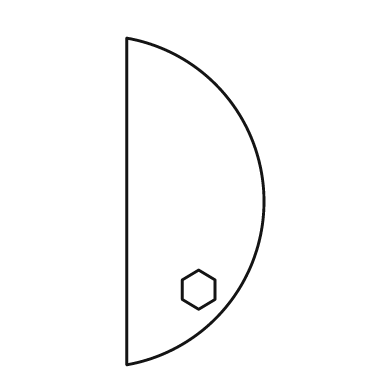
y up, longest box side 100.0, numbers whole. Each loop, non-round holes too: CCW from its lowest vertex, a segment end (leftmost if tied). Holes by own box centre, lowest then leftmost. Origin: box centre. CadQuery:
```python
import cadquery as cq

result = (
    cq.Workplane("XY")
    .moveTo(-21.0, -50.0)
    .threePointArc((21.0, 0.0), (-21.0, 50.0))
    .close()
    .moveTo(1.0, -33.0)
    .lineTo(6.0, -30.0)
    .lineTo(6.0, -24.0)
    .lineTo(1.0, -21.0)
    .lineTo(-4.0, -24.0)
    .lineTo(-4.0, -30.0)
    .close()
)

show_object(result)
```